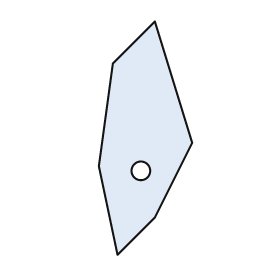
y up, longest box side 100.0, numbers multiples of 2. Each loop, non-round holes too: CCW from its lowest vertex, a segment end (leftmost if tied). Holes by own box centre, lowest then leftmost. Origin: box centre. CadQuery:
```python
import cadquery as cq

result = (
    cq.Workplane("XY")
    .moveTo(-12.0, -50.0)
    .lineTo(4.0, -34.0)
    .lineTo(20.0, -2.0)
    .lineTo(4.0, 50.0)
    .lineTo(-14.0, 32.0)
    .lineTo(-20.0, -12.0)
    .close()
    .moveTo(-2.0, -14.0)
    .circle(4.0)
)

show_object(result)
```